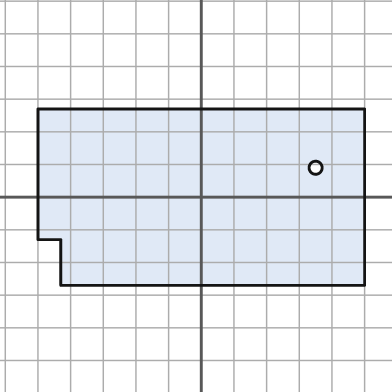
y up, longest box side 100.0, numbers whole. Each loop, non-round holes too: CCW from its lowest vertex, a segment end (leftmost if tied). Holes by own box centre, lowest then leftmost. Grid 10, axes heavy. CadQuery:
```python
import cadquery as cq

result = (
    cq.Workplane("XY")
    .moveTo(-43.0, -27.0)
    .lineTo(50.0, -27.0)
    .lineTo(50.0, 27.0)
    .lineTo(-50.0, 27.0)
    .lineTo(-50.0, -13.0)
    .lineTo(-43.0, -13.0)
    .close()
    .moveTo(35.0, 9.0)
    .circle(2.0)
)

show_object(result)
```